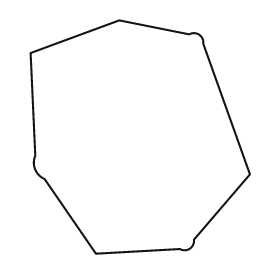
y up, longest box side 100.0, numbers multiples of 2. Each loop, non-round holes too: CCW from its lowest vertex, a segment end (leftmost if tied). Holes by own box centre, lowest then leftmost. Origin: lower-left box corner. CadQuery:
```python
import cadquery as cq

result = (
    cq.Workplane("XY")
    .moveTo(28.0, 0.0)
    .lineTo(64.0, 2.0)
    .threePointArc((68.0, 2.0), (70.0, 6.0))
    .lineTo(94.0, 34.0)
    .lineTo(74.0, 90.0)
    .threePointArc((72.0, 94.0), (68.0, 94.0))
    .lineTo(38.0, 100.0)
    .lineTo(0.0, 86.0)
    .lineTo(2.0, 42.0)
    .threePointArc((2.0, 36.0), (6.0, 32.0))
    .close()
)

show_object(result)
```